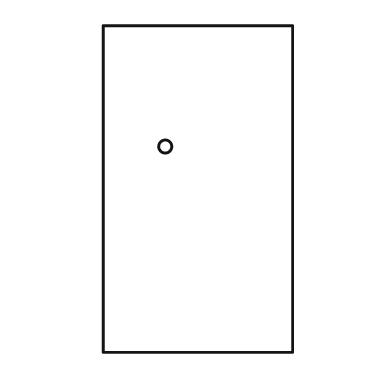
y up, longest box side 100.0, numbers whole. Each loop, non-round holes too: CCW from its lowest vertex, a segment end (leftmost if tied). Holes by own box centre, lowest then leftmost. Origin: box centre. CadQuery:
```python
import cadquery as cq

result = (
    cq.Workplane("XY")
    .moveTo(-29.0, -50.0)
    .lineTo(29.0, -50.0)
    .lineTo(29.0, 50.0)
    .lineTo(-29.0, 50.0)
    .close()
    .moveTo(-10.0, 13.0)
    .circle(2.0)
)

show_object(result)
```